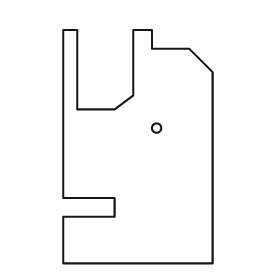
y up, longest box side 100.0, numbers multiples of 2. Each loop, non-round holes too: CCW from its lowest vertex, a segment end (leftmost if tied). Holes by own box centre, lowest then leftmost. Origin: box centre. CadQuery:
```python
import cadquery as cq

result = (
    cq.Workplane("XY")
    .moveTo(-32.0, -50.0)
    .lineTo(32.0, -50.0)
    .lineTo(32.0, 32.0)
    .lineTo(22.0, 42.0)
    .lineTo(6.0, 42.0)
    .lineTo(6.0, 50.0)
    .lineTo(-2.0, 50.0)
    .lineTo(-2.0, 22.0)
    .lineTo(-10.0, 16.0)
    .lineTo(-26.0, 16.0)
    .lineTo(-26.0, 50.0)
    .lineTo(-32.0, 50.0)
    .lineTo(-32.0, -22.0)
    .lineTo(-10.0, -22.0)
    .lineTo(-10.0, -30.0)
    .lineTo(-32.0, -30.0)
    .close()
    .moveTo(8.0, 8.0)
    .circle(2.0)
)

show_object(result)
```